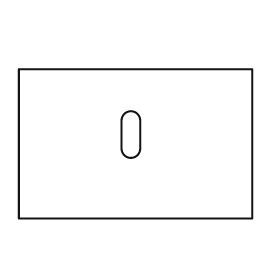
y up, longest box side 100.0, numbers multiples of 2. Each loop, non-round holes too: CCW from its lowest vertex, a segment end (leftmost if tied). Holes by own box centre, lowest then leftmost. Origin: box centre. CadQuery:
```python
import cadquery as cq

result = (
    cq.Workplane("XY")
    .moveTo(-50.0, -32.0)
    .lineTo(50.0, -32.0)
    .lineTo(50.0, 32.0)
    .lineTo(-50.0, 32.0)
    .close()
    .moveTo(-6.0, -2.0)
    .threePointArc((-2.0, -6.0), (2.0, -2.0))
    .lineTo(2.0, 10.0)
    .threePointArc((-2.0, 14.0), (-6.0, 10.0))
    .close()
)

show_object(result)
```